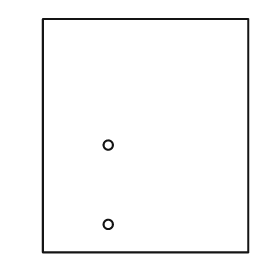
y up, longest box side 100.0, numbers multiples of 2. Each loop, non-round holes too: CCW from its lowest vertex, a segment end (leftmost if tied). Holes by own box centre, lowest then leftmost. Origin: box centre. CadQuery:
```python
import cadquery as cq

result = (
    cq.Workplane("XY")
    .moveTo(-44.0, -50.0)
    .lineTo(44.0, -50.0)
    .lineTo(44.0, 50.0)
    .lineTo(-44.0, 50.0)
    .close()
    .moveTo(-16.0, -38.0)
    .circle(2.0)
    .moveTo(-16.0, -4.0)
    .circle(2.0)
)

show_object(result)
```